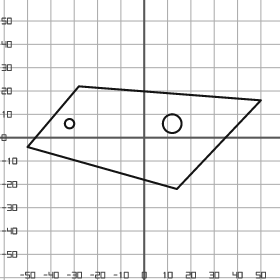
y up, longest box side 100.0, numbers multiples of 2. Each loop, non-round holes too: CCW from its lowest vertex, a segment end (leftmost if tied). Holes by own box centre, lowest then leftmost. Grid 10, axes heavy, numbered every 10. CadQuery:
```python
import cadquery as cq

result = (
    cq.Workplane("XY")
    .moveTo(14.0, -22.0)
    .lineTo(50.0, 16.0)
    .lineTo(-28.0, 22.0)
    .lineTo(-50.0, -4.0)
    .close()
    .moveTo(-32.0, 6.0)
    .circle(2.0)
    .moveTo(12.0, 6.0)
    .circle(4.0)
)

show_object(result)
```